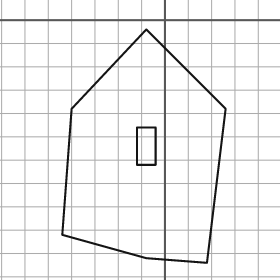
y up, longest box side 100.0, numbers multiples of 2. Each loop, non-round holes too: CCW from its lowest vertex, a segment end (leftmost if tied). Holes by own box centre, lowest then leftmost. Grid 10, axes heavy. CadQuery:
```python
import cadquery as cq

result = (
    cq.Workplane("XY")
    .moveTo(18.0, -104.0)
    .lineTo(26.0, -38.0)
    .lineTo(-8.0, -4.0)
    .lineTo(-40.0, -38.0)
    .lineTo(-44.0, -92.0)
    .lineTo(-8.0, -102.0)
    .close()
    .moveTo(-12.0, -62.0)
    .lineTo(-4.0, -62.0)
    .lineTo(-4.0, -46.0)
    .lineTo(-12.0, -46.0)
    .close()
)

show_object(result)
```